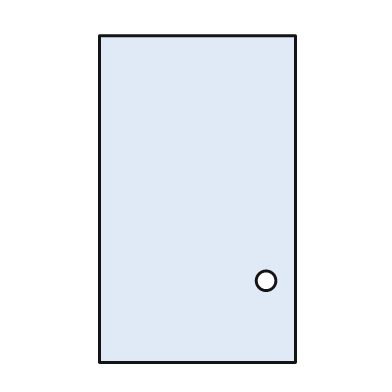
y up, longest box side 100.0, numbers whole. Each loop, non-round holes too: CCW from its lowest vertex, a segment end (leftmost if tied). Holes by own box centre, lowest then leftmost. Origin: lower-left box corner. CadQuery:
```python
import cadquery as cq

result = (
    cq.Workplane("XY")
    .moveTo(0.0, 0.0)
    .lineTo(60.0, 0.0)
    .lineTo(60.0, 100.0)
    .lineTo(0.0, 100.0)
    .close()
    .moveTo(51.0, 25.0)
    .circle(3.0)
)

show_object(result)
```